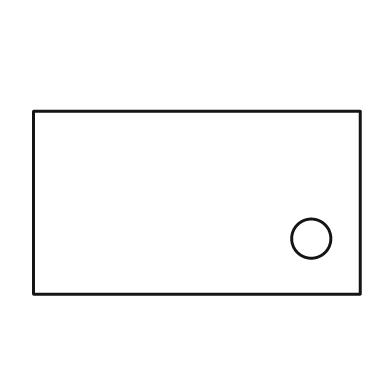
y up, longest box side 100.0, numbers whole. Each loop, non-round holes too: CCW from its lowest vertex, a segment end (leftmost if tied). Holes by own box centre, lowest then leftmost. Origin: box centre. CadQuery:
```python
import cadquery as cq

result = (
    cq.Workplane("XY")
    .moveTo(-50.0, -28.0)
    .lineTo(50.0, -28.0)
    .lineTo(50.0, 28.0)
    .lineTo(-50.0, 28.0)
    .close()
    .moveTo(35.0, -11.0)
    .circle(6.0)
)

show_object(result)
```